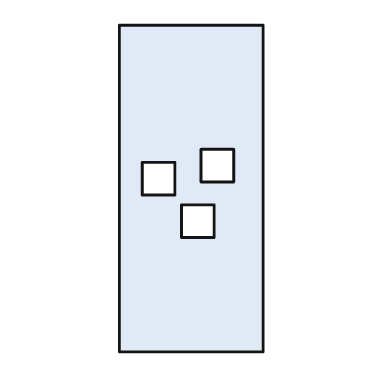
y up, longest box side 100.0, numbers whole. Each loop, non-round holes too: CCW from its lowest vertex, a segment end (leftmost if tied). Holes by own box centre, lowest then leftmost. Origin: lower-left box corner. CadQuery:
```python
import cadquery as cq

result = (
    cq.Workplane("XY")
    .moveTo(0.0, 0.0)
    .lineTo(44.0, 0.0)
    .lineTo(44.0, 100.0)
    .lineTo(0.0, 100.0)
    .close()
    .moveTo(19.0, 35.0)
    .lineTo(29.0, 35.0)
    .lineTo(29.0, 45.0)
    .lineTo(19.0, 45.0)
    .close()
    .moveTo(7.0, 48.0)
    .lineTo(17.0, 48.0)
    .lineTo(17.0, 58.0)
    .lineTo(7.0, 58.0)
    .close()
    .moveTo(25.0, 52.0)
    .lineTo(35.0, 52.0)
    .lineTo(35.0, 62.0)
    .lineTo(25.0, 62.0)
    .close()
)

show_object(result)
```